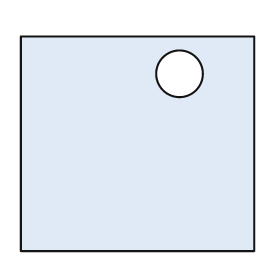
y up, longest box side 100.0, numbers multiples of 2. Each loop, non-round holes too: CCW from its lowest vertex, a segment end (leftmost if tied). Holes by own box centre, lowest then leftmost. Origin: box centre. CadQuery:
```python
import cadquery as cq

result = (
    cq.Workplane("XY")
    .moveTo(-50.0, -46.0)
    .lineTo(50.0, -46.0)
    .lineTo(50.0, 46.0)
    .lineTo(-50.0, 46.0)
    .close()
    .moveTo(18.0, 30.0)
    .circle(10.0)
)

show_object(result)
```